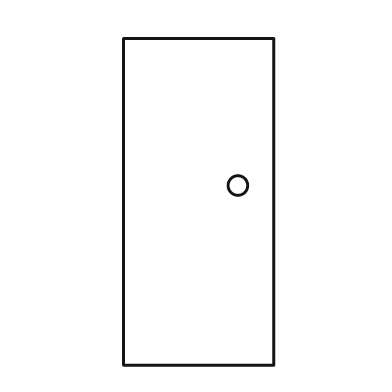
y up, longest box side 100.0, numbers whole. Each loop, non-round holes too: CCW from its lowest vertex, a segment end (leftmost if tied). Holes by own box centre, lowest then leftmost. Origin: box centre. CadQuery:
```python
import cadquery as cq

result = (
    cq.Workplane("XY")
    .moveTo(-23.0, -50.0)
    .lineTo(23.0, -50.0)
    .lineTo(23.0, 50.0)
    .lineTo(-23.0, 50.0)
    .close()
    .moveTo(12.0, 5.0)
    .circle(3.0)
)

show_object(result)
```